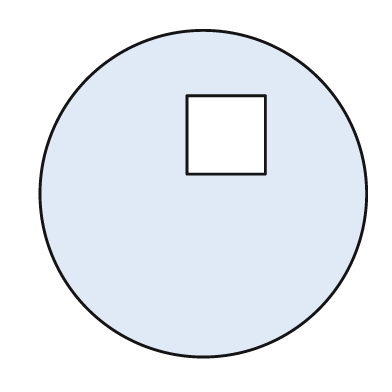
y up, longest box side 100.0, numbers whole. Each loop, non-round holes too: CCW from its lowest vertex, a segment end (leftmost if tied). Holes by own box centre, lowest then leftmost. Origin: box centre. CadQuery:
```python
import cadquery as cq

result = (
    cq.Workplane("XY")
    .moveTo(0.0, 0.0)
    .circle(50.0)
    .moveTo(-5.0, 6.0)
    .lineTo(19.0, 6.0)
    .lineTo(19.0, 30.0)
    .lineTo(-5.0, 30.0)
    .close()
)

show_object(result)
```